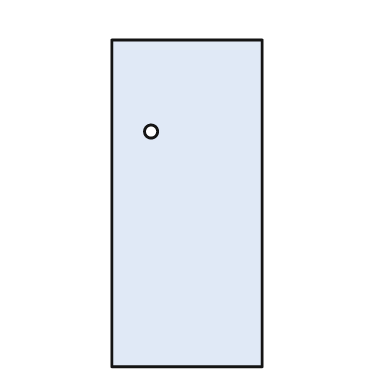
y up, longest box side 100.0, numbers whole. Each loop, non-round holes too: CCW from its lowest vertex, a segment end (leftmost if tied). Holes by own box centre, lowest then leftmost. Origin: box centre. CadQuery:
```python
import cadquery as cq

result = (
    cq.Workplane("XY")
    .moveTo(-23.0, -50.0)
    .lineTo(23.0, -50.0)
    .lineTo(23.0, 50.0)
    .lineTo(-23.0, 50.0)
    .close()
    .moveTo(-11.0, 22.0)
    .circle(2.0)
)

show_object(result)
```